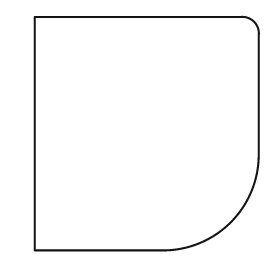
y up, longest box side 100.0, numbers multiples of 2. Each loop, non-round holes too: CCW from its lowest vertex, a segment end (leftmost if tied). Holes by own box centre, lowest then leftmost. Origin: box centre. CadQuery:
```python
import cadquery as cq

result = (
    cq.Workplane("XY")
    .moveTo(-48.0, -50.0)
    .lineTo(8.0, -50.0)
    .threePointArc((36.0, -38.0), (48.0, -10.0))
    .lineTo(48.0, 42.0)
    .threePointArc((46.0, 48.0), (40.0, 50.0))
    .lineTo(-48.0, 50.0)
    .close()
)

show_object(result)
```